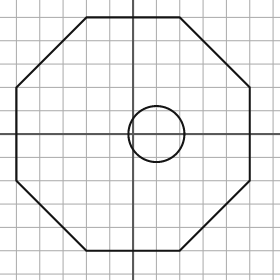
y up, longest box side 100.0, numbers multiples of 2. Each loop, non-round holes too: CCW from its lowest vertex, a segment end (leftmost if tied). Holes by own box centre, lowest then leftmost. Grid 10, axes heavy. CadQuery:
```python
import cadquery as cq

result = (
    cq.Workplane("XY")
    .moveTo(-20.0, -50.0)
    .lineTo(20.0, -50.0)
    .lineTo(50.0, -20.0)
    .lineTo(50.0, 20.0)
    .lineTo(20.0, 50.0)
    .lineTo(-20.0, 50.0)
    .lineTo(-50.0, 20.0)
    .lineTo(-50.0, -20.0)
    .close()
    .moveTo(10.0, 0.0)
    .circle(12.0)
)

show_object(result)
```